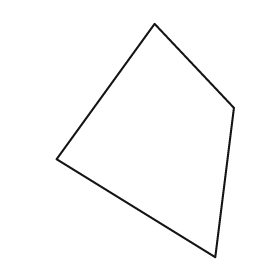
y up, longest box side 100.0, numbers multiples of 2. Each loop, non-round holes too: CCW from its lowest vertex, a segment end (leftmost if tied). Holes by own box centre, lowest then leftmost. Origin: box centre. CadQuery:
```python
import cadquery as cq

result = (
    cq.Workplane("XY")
    .moveTo(30.0, -50.0)
    .lineTo(38.0, 14.0)
    .lineTo(4.0, 50.0)
    .lineTo(-38.0, -8.0)
    .close()
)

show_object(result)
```